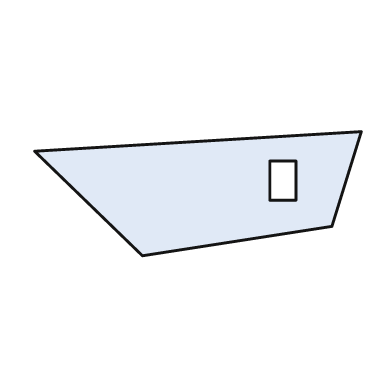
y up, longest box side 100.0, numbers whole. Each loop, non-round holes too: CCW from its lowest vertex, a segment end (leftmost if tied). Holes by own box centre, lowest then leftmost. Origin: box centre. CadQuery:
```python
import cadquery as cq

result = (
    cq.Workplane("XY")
    .moveTo(-17.0, -19.0)
    .lineTo(41.0, -10.0)
    .lineTo(50.0, 19.0)
    .lineTo(-50.0, 13.0)
    .close()
    .moveTo(22.0, -2.0)
    .lineTo(30.0, -2.0)
    .lineTo(30.0, 10.0)
    .lineTo(22.0, 10.0)
    .close()
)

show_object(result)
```